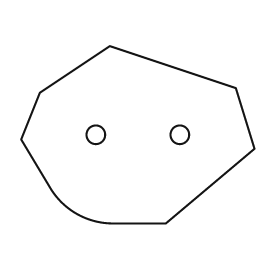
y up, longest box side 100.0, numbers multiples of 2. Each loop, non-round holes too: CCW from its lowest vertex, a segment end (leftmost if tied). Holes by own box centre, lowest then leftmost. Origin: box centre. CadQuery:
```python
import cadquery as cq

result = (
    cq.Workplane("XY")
    .moveTo(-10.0, -38.0)
    .lineTo(12.0, -38.0)
    .lineTo(50.0, -6.0)
    .lineTo(42.0, 20.0)
    .lineTo(-12.0, 38.0)
    .lineTo(-42.0, 18.0)
    .lineTo(-50.0, -2.0)
    .lineTo(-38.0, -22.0)
    .threePointArc((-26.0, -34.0), (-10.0, -38.0))
    .close()
    .moveTo(-18.0, 0.0)
    .circle(4.0)
    .moveTo(18.0, 0.0)
    .circle(4.0)
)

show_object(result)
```